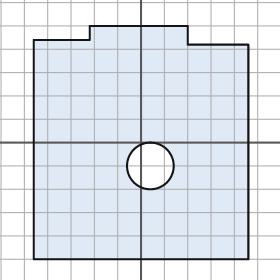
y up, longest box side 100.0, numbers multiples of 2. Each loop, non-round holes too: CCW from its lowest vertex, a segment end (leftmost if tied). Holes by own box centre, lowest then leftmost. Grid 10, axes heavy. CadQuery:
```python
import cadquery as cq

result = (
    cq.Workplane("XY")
    .moveTo(-46.0, -50.0)
    .lineTo(46.0, -50.0)
    .lineTo(46.0, 42.0)
    .lineTo(20.0, 42.0)
    .lineTo(20.0, 50.0)
    .lineTo(-22.0, 50.0)
    .lineTo(-22.0, 44.0)
    .lineTo(-46.0, 44.0)
    .close()
    .moveTo(4.0, -10.0)
    .circle(10.0)
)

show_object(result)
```